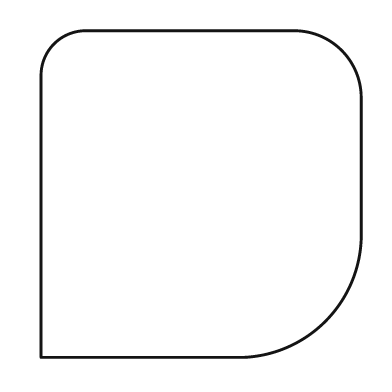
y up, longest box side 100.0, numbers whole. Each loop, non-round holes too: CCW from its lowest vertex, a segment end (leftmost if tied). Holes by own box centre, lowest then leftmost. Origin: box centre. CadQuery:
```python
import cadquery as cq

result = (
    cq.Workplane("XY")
    .moveTo(-49.0, -50.0)
    .lineTo(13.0, -50.0)
    .threePointArc((38.0, -39.0), (49.0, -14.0))
    .lineTo(49.0, 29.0)
    .threePointArc((43.0, 44.0), (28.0, 50.0))
    .lineTo(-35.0, 50.0)
    .threePointArc((-45.0, 46.0), (-49.0, 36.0))
    .close()
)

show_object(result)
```